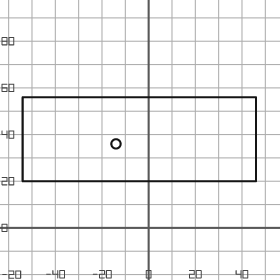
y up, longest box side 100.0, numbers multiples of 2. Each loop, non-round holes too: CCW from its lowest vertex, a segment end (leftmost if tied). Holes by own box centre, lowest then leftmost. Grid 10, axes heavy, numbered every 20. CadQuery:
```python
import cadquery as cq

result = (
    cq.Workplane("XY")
    .moveTo(-54.0, 20.0)
    .lineTo(46.0, 20.0)
    .lineTo(46.0, 56.0)
    .lineTo(-54.0, 56.0)
    .close()
    .moveTo(-14.0, 36.0)
    .circle(2.0)
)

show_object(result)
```